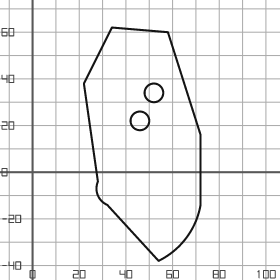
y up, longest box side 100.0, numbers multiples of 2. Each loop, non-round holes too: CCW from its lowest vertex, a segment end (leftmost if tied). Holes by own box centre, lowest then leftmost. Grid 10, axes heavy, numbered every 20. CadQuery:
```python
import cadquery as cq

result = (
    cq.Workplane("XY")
    .moveTo(54.0, -38.0)
    .threePointArc((66.0, -28.0), (72.0, -14.0))
    .lineTo(72.0, 16.0)
    .lineTo(58.0, 60.0)
    .lineTo(34.0, 62.0)
    .lineTo(22.0, 38.0)
    .lineTo(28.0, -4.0)
    .threePointArc((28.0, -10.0), (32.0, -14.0))
    .close()
    .moveTo(46.0, 22.0)
    .circle(4.0)
    .moveTo(52.0, 34.0)
    .circle(4.0)
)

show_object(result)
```